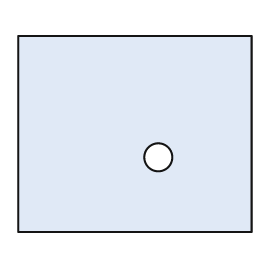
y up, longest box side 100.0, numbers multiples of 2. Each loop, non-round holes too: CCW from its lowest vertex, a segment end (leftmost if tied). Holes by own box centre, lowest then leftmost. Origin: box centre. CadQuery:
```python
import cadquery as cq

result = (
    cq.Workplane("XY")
    .moveTo(-50.0, -42.0)
    .lineTo(50.0, -42.0)
    .lineTo(50.0, 42.0)
    .lineTo(-50.0, 42.0)
    .close()
    .moveTo(10.0, -10.0)
    .circle(6.0)
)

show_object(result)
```